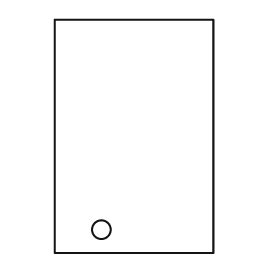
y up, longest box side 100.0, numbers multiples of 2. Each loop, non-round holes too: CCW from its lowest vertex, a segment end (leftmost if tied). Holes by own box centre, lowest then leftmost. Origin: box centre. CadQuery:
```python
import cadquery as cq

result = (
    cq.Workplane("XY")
    .moveTo(-34.0, -50.0)
    .lineTo(34.0, -50.0)
    .lineTo(34.0, 50.0)
    .lineTo(-34.0, 50.0)
    .close()
    .moveTo(-14.0, -40.0)
    .circle(4.0)
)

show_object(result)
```